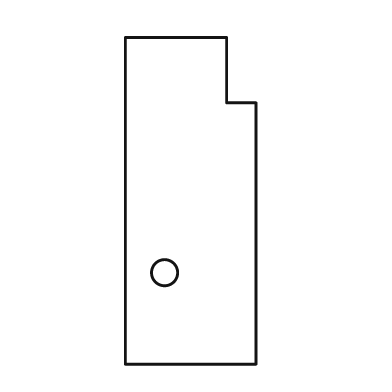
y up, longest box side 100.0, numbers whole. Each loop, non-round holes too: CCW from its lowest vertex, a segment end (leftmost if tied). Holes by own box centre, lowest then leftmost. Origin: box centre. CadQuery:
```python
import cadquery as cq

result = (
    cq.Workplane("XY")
    .moveTo(-20.0, -50.0)
    .lineTo(20.0, -50.0)
    .lineTo(20.0, 30.0)
    .lineTo(11.0, 30.0)
    .lineTo(11.0, 50.0)
    .lineTo(-20.0, 50.0)
    .close()
    .moveTo(-8.0, -22.0)
    .circle(4.0)
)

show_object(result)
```